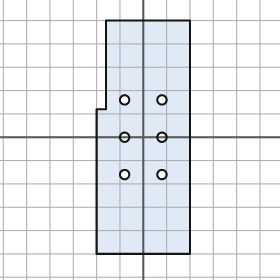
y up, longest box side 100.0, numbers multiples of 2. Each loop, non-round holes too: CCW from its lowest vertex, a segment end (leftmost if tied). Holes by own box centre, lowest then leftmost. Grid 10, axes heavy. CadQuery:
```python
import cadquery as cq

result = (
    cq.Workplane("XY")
    .moveTo(-20.0, -50.0)
    .lineTo(20.0, -50.0)
    .lineTo(20.0, 50.0)
    .lineTo(-16.0, 50.0)
    .lineTo(-16.0, 12.0)
    .lineTo(-20.0, 12.0)
    .close()
    .moveTo(-8.0, -16.0)
    .circle(2.0)
    .moveTo(8.0, -16.0)
    .circle(2.0)
    .moveTo(-8.0, 0.0)
    .circle(2.0)
    .moveTo(8.0, 0.0)
    .circle(2.0)
    .moveTo(-8.0, 16.0)
    .circle(2.0)
    .moveTo(8.0, 16.0)
    .circle(2.0)
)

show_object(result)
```